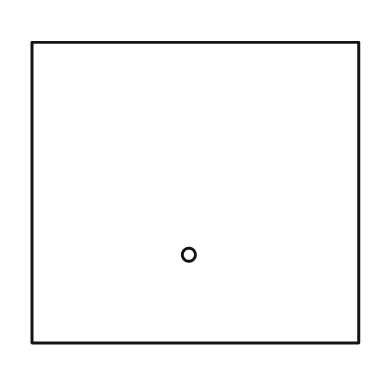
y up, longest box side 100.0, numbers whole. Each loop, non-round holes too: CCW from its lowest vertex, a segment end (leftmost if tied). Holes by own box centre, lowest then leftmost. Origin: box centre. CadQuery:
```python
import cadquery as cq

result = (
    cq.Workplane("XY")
    .moveTo(-50.0, -46.0)
    .lineTo(50.0, -46.0)
    .lineTo(50.0, 46.0)
    .lineTo(-50.0, 46.0)
    .close()
    .moveTo(-2.0, -19.0)
    .circle(2.0)
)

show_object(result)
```